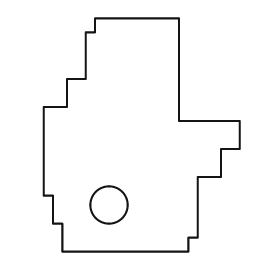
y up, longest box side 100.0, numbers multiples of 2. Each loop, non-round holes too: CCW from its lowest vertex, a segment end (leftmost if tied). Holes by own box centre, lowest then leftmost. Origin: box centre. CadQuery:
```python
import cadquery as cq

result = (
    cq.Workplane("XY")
    .moveTo(-34.0, -50.0)
    .lineTo(20.0, -50.0)
    .lineTo(20.0, -44.0)
    .lineTo(24.0, -44.0)
    .lineTo(24.0, -18.0)
    .lineTo(34.0, -18.0)
    .lineTo(34.0, -6.0)
    .lineTo(42.0, -6.0)
    .lineTo(42.0, 6.0)
    .lineTo(16.0, 6.0)
    .lineTo(16.0, 50.0)
    .lineTo(-20.0, 50.0)
    .lineTo(-20.0, 44.0)
    .lineTo(-24.0, 44.0)
    .lineTo(-24.0, 24.0)
    .lineTo(-32.0, 24.0)
    .lineTo(-32.0, 12.0)
    .lineTo(-42.0, 12.0)
    .lineTo(-42.0, -26.0)
    .lineTo(-38.0, -26.0)
    .lineTo(-38.0, -38.0)
    .lineTo(-34.0, -38.0)
    .close()
    .moveTo(-14.0, -30.0)
    .circle(8.0)
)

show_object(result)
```